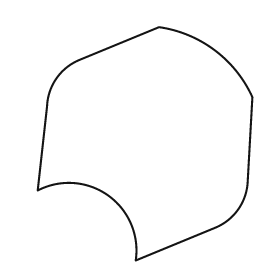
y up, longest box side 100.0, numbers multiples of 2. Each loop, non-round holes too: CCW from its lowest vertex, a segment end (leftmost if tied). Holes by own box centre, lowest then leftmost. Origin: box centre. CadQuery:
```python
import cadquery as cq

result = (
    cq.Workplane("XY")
    .moveTo(-4.0, -50.0)
    .lineTo(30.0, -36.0)
    .threePointArc((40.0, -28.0), (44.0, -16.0))
    .lineTo(46.0, 20.0)
    .threePointArc((30.0, 40.0), (6.0, 50.0))
    .lineTo(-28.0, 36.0)
    .threePointArc((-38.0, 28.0), (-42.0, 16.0))
    .lineTo(-46.0, -20.0)
    .threePointArc((-16.0, -22.0), (-4.0, -50.0))
    .close()
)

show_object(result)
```